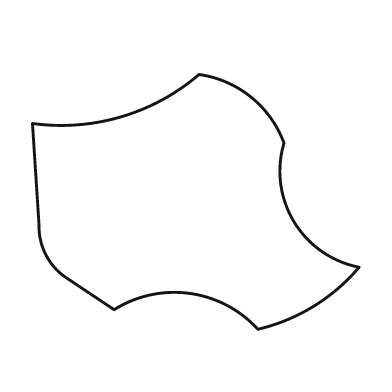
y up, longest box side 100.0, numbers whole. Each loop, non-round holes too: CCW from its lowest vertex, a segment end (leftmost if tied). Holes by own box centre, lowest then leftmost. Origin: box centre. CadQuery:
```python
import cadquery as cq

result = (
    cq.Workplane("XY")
    .moveTo(19.0, -39.0)
    .threePointArc((36.0, -32.0), (50.0, -20.0))
    .threePointArc((30.0, -6.0), (27.0, 18.0))
    .threePointArc((17.0, 32.0), (1.0, 39.0))
    .threePointArc((-23.0, 26.0), (-50.0, 24.0))
    .lineTo(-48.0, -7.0)
    .threePointArc((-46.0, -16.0), (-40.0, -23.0))
    .lineTo(-25.0, -33.0)
    .threePointArc((-2.0, -28.0), (19.0, -39.0))
    .close()
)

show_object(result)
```